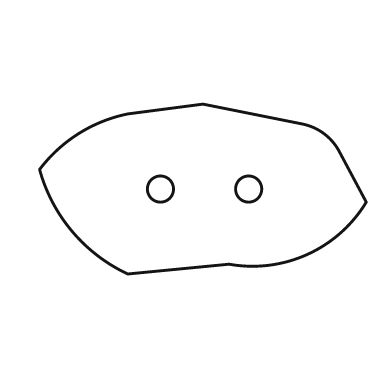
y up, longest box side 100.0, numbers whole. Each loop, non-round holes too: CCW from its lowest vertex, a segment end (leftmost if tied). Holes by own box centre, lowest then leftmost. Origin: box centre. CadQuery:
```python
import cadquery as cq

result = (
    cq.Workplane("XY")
    .moveTo(-23.0, -26.0)
    .lineTo(8.0, -23.0)
    .threePointArc((32.0, -20.0), (50.0, -4.0))
    .lineTo(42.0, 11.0)
    .threePointArc((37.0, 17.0), (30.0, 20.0))
    .lineTo(0.0, 26.0)
    .lineTo(-23.0, 23.0)
    .threePointArc((-38.0, 17.0), (-50.0, 6.0))
    .threePointArc((-40.0, -13.0), (-23.0, -26.0))
    .close()
    .moveTo(-13.0, 0.0)
    .circle(4.0)
    .moveTo(14.0, 0.0)
    .circle(4.0)
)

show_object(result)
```